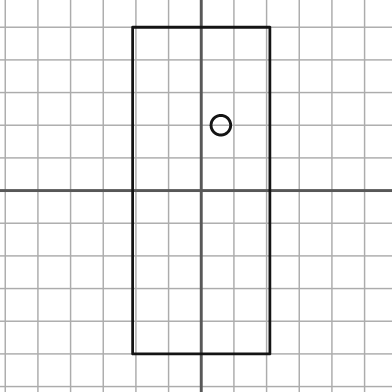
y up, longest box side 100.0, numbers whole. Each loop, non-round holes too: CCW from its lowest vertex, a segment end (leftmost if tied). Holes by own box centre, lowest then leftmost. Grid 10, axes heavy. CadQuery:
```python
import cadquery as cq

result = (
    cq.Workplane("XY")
    .moveTo(-21.0, -50.0)
    .lineTo(21.0, -50.0)
    .lineTo(21.0, 50.0)
    .lineTo(-21.0, 50.0)
    .close()
    .moveTo(6.0, 20.0)
    .circle(3.0)
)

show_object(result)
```